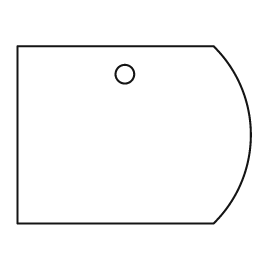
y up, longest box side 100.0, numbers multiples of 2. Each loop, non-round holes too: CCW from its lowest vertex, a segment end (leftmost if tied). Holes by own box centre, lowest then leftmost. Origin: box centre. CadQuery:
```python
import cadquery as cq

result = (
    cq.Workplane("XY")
    .moveTo(-50.0, -38.0)
    .lineTo(34.0, -38.0)
    .threePointArc((50.0, 0.0), (34.0, 38.0))
    .lineTo(-50.0, 38.0)
    .close()
    .moveTo(-4.0, 26.0)
    .circle(4.0)
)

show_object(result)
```